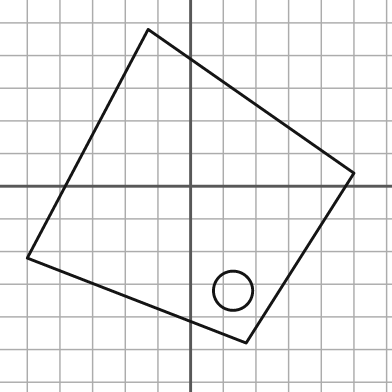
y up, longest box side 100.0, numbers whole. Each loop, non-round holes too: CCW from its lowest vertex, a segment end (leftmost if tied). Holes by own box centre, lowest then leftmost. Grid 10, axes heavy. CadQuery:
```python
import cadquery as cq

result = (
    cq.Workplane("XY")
    .moveTo(17.0, -48.0)
    .lineTo(50.0, 4.0)
    .lineTo(-13.0, 48.0)
    .lineTo(-50.0, -22.0)
    .close()
    .moveTo(13.0, -32.0)
    .circle(6.0)
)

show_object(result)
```